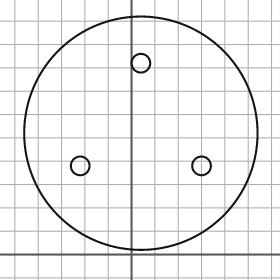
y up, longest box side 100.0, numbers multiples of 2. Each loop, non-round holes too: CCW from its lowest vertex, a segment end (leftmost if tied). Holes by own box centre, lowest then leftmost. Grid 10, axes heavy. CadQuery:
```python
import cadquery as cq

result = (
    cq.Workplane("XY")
    .moveTo(4.0, 52.0)
    .circle(50.0)
    .moveTo(-22.0, 38.0)
    .circle(4.0)
    .moveTo(30.0, 38.0)
    .circle(4.0)
    .moveTo(4.0, 82.0)
    .circle(4.0)
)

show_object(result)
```